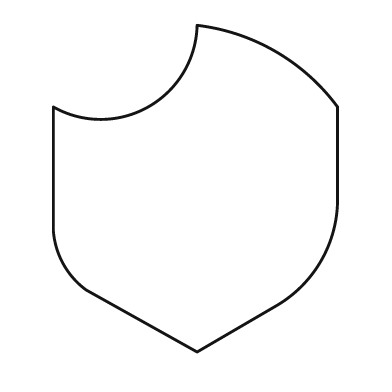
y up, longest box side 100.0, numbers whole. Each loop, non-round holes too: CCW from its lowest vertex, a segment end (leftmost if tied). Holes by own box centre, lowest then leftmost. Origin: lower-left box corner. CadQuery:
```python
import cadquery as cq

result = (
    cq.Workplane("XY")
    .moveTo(44.0, 0.0)
    .lineTo(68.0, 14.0)
    .threePointArc((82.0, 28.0), (87.0, 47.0))
    .lineTo(87.0, 75.0)
    .threePointArc((68.0, 92.0), (44.0, 100.0))
    .threePointArc((29.0, 75.0), (0.0, 75.0))
    .lineTo(0.0, 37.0)
    .threePointArc((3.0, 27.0), (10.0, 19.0))
    .close()
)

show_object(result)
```